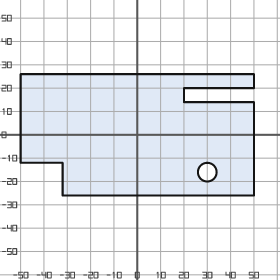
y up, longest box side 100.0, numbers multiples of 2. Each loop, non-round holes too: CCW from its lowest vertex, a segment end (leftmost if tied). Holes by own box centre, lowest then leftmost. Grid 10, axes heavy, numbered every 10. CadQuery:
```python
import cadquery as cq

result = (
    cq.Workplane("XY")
    .moveTo(-32.0, -26.0)
    .lineTo(50.0, -26.0)
    .lineTo(50.0, 14.0)
    .lineTo(20.0, 14.0)
    .lineTo(20.0, 20.0)
    .lineTo(50.0, 20.0)
    .lineTo(50.0, 26.0)
    .lineTo(-50.0, 26.0)
    .lineTo(-50.0, -12.0)
    .lineTo(-32.0, -12.0)
    .close()
    .moveTo(30.0, -16.0)
    .circle(4.0)
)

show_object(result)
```